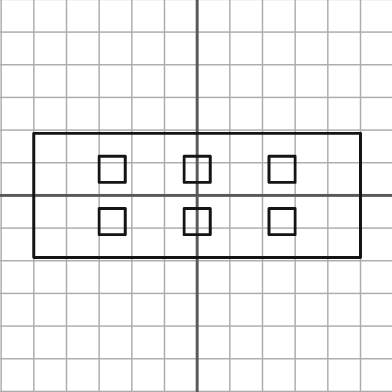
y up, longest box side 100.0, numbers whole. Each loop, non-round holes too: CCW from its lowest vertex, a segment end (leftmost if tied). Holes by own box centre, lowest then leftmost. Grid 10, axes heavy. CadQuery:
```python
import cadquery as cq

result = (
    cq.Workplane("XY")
    .moveTo(-50.0, -19.0)
    .lineTo(50.0, -19.0)
    .lineTo(50.0, 19.0)
    .lineTo(-50.0, 19.0)
    .close()
    .moveTo(-30.0, -12.0)
    .lineTo(-22.0, -12.0)
    .lineTo(-22.0, -4.0)
    .lineTo(-30.0, -4.0)
    .close()
    .moveTo(-4.0, -12.0)
    .lineTo(4.0, -12.0)
    .lineTo(4.0, -4.0)
    .lineTo(-4.0, -4.0)
    .close()
    .moveTo(22.0, -12.0)
    .lineTo(30.0, -12.0)
    .lineTo(30.0, -4.0)
    .lineTo(22.0, -4.0)
    .close()
    .moveTo(-30.0, 4.0)
    .lineTo(-22.0, 4.0)
    .lineTo(-22.0, 12.0)
    .lineTo(-30.0, 12.0)
    .close()
    .moveTo(-4.0, 4.0)
    .lineTo(4.0, 4.0)
    .lineTo(4.0, 12.0)
    .lineTo(-4.0, 12.0)
    .close()
    .moveTo(22.0, 4.0)
    .lineTo(30.0, 4.0)
    .lineTo(30.0, 12.0)
    .lineTo(22.0, 12.0)
    .close()
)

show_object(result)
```